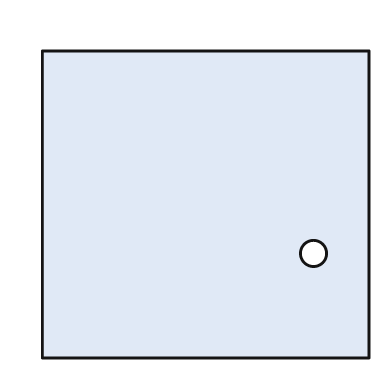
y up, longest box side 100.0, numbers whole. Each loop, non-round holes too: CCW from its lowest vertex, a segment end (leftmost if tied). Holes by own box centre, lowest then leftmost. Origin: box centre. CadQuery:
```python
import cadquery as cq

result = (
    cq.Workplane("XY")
    .moveTo(-50.0, -47.0)
    .lineTo(50.0, -47.0)
    .lineTo(50.0, 47.0)
    .lineTo(-50.0, 47.0)
    .close()
    .moveTo(33.0, -15.0)
    .circle(4.0)
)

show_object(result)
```